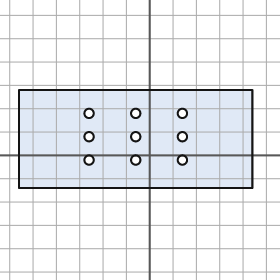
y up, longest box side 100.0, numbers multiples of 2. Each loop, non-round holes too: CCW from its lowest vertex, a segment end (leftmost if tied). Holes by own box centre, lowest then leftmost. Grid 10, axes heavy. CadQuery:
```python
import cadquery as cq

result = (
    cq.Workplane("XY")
    .moveTo(-56.0, -14.0)
    .lineTo(44.0, -14.0)
    .lineTo(44.0, 28.0)
    .lineTo(-56.0, 28.0)
    .close()
    .moveTo(-26.0, -2.0)
    .circle(2.0)
    .moveTo(-6.0, -2.0)
    .circle(2.0)
    .moveTo(14.0, -2.0)
    .circle(2.0)
    .moveTo(-26.0, 8.0)
    .circle(2.0)
    .moveTo(-6.0, 8.0)
    .circle(2.0)
    .moveTo(14.0, 8.0)
    .circle(2.0)
    .moveTo(-26.0, 18.0)
    .circle(2.0)
    .moveTo(-6.0, 18.0)
    .circle(2.0)
    .moveTo(14.0, 18.0)
    .circle(2.0)
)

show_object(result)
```